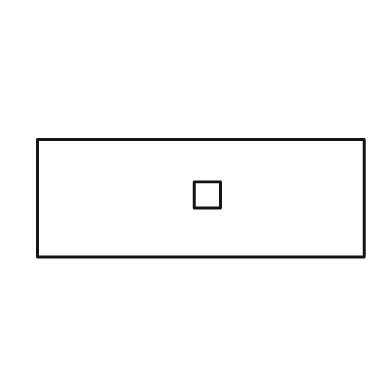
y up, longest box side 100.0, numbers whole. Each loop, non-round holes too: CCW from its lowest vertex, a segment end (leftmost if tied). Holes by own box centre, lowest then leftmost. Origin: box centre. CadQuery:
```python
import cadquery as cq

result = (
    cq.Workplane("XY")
    .moveTo(-50.0, -18.0)
    .lineTo(50.0, -18.0)
    .lineTo(50.0, 18.0)
    .lineTo(-50.0, 18.0)
    .close()
    .moveTo(-2.0, -3.0)
    .lineTo(6.0, -3.0)
    .lineTo(6.0, 5.0)
    .lineTo(-2.0, 5.0)
    .close()
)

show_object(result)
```